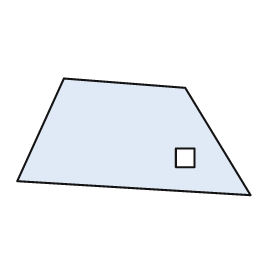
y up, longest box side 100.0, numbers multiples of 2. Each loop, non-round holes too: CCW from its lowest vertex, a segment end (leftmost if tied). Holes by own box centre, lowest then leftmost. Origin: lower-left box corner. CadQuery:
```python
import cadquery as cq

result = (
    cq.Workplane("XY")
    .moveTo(100.0, 0.0)
    .lineTo(72.0, 46.0)
    .lineTo(20.0, 50.0)
    .lineTo(0.0, 6.0)
    .close()
    .moveTo(68.0, 12.0)
    .lineTo(76.0, 12.0)
    .lineTo(76.0, 20.0)
    .lineTo(68.0, 20.0)
    .close()
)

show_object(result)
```